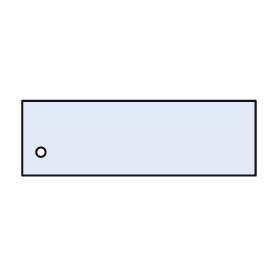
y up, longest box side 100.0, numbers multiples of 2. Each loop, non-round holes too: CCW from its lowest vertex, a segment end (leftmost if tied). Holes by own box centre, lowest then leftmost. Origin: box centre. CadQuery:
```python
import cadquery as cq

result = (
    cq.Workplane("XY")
    .moveTo(-50.0, -16.0)
    .lineTo(50.0, -16.0)
    .lineTo(50.0, 16.0)
    .lineTo(-50.0, 16.0)
    .close()
    .moveTo(-42.0, -6.0)
    .circle(2.0)
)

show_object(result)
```